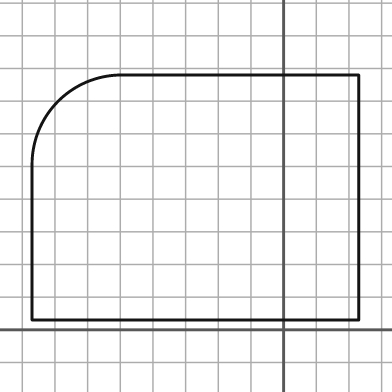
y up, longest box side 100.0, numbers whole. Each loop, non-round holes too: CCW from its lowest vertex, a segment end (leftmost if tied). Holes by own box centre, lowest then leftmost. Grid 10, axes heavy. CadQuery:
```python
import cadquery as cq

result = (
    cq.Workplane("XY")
    .moveTo(-77.0, 3.0)
    .lineTo(23.0, 3.0)
    .lineTo(23.0, 78.0)
    .lineTo(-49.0, 78.0)
    .threePointArc((-69.0, 70.0), (-77.0, 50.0))
    .close()
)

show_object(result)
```